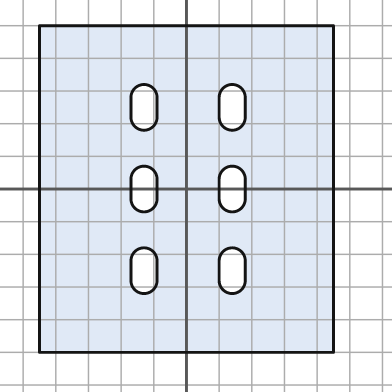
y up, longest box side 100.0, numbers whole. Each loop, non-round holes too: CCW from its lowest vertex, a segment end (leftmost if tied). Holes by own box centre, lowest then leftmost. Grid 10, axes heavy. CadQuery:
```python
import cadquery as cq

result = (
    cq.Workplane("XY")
    .moveTo(-45.0, -50.0)
    .lineTo(45.0, -50.0)
    .lineTo(45.0, 50.0)
    .lineTo(-45.0, 50.0)
    .close()
    .moveTo(-17.0, -28.0)
    .threePointArc((-13.0, -32.0), (-9.0, -28.0))
    .lineTo(-9.0, -22.0)
    .threePointArc((-13.0, -18.0), (-17.0, -22.0))
    .close()
    .moveTo(10.0, -28.0)
    .threePointArc((14.0, -32.0), (18.0, -28.0))
    .lineTo(18.0, -22.0)
    .threePointArc((14.0, -18.0), (10.0, -22.0))
    .close()
    .moveTo(-17.0, -3.0)
    .threePointArc((-13.0, -7.0), (-9.0, -3.0))
    .lineTo(-9.0, 3.0)
    .threePointArc((-13.0, 7.0), (-17.0, 3.0))
    .close()
    .moveTo(10.0, -3.0)
    .threePointArc((14.0, -7.0), (18.0, -3.0))
    .lineTo(18.0, 3.0)
    .threePointArc((14.0, 7.0), (10.0, 3.0))
    .close()
    .moveTo(-17.0, 22.0)
    .threePointArc((-13.0, 18.0), (-9.0, 22.0))
    .lineTo(-9.0, 28.0)
    .threePointArc((-13.0, 32.0), (-17.0, 28.0))
    .close()
    .moveTo(10.0, 22.0)
    .threePointArc((14.0, 18.0), (18.0, 22.0))
    .lineTo(18.0, 28.0)
    .threePointArc((14.0, 32.0), (10.0, 28.0))
    .close()
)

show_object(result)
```